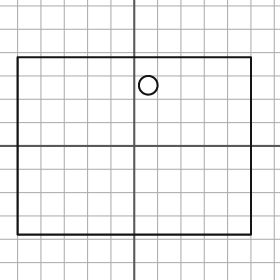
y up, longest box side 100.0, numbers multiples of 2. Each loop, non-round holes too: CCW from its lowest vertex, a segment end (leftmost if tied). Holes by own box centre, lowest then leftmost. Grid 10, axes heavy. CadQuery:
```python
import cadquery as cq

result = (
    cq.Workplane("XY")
    .moveTo(-50.0, -38.0)
    .lineTo(50.0, -38.0)
    .lineTo(50.0, 38.0)
    .lineTo(-50.0, 38.0)
    .close()
    .moveTo(6.0, 26.0)
    .circle(4.0)
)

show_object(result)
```